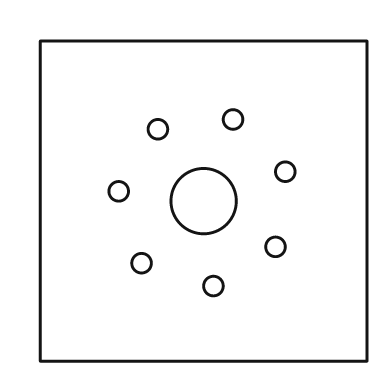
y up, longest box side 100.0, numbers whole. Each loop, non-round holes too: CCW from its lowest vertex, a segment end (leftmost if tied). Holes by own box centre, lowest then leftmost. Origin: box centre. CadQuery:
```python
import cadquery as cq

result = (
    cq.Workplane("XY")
    .moveTo(-50.0, -49.0)
    .lineTo(50.0, -49.0)
    .lineTo(50.0, 49.0)
    .lineTo(-50.0, 49.0)
    .close()
    .moveTo(3.0, -26.0)
    .circle(3.0)
    .moveTo(-19.0, -19.0)
    .circle(3.0)
    .moveTo(22.0, -14.0)
    .circle(3.0)
    .moveTo(0.0, 0.0)
    .circle(10.0)
    .moveTo(-26.0, 3.0)
    .circle(3.0)
    .moveTo(25.0, 9.0)
    .circle(3.0)
    .moveTo(-14.0, 22.0)
    .circle(3.0)
    .moveTo(9.0, 25.0)
    .circle(3.0)
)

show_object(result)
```